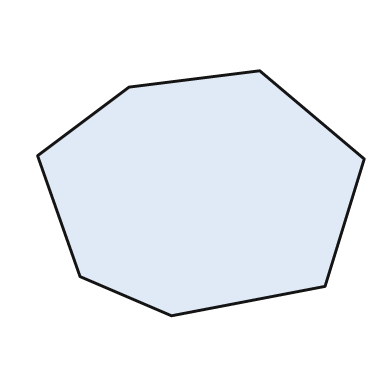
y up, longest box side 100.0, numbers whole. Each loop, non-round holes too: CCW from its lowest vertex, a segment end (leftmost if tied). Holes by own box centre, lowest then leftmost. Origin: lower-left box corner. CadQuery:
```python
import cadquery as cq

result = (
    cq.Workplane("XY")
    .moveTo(41.0, 0.0)
    .lineTo(88.0, 9.0)
    .lineTo(100.0, 48.0)
    .lineTo(68.0, 75.0)
    .lineTo(28.0, 70.0)
    .lineTo(0.0, 49.0)
    .lineTo(13.0, 12.0)
    .close()
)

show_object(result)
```